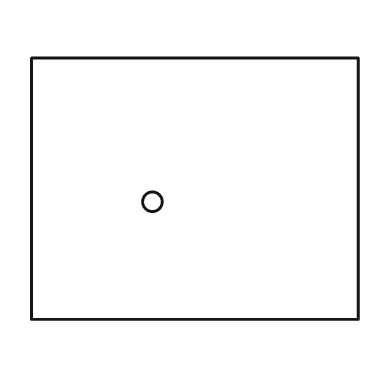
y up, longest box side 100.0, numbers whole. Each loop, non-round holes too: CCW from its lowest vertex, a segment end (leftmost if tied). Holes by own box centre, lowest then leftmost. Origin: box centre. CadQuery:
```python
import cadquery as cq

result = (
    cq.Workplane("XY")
    .moveTo(-50.0, -40.0)
    .lineTo(50.0, -40.0)
    .lineTo(50.0, 40.0)
    .lineTo(-50.0, 40.0)
    .close()
    .moveTo(-13.0, -4.0)
    .circle(3.0)
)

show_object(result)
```